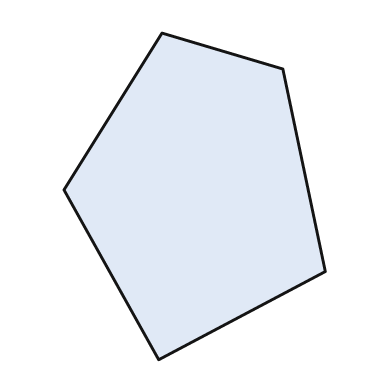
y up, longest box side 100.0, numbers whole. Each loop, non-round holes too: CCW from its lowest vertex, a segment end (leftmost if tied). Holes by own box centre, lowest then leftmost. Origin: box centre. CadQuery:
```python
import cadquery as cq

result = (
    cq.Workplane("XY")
    .moveTo(-11.0, -50.0)
    .lineTo(40.0, -23.0)
    .lineTo(27.0, 39.0)
    .lineTo(-10.0, 50.0)
    .lineTo(-40.0, 2.0)
    .close()
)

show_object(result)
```